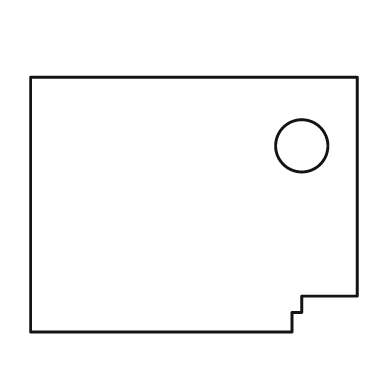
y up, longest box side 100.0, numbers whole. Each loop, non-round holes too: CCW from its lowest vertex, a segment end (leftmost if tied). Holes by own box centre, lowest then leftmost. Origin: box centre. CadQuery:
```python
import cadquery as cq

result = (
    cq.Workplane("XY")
    .moveTo(-50.0, -39.0)
    .lineTo(30.0, -39.0)
    .lineTo(30.0, -33.0)
    .lineTo(33.0, -33.0)
    .lineTo(33.0, -28.0)
    .lineTo(50.0, -28.0)
    .lineTo(50.0, 39.0)
    .lineTo(-50.0, 39.0)
    .close()
    .moveTo(33.0, 18.0)
    .circle(8.0)
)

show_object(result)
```